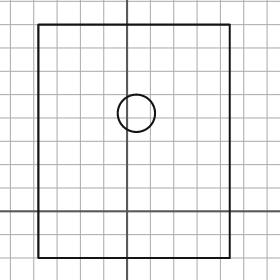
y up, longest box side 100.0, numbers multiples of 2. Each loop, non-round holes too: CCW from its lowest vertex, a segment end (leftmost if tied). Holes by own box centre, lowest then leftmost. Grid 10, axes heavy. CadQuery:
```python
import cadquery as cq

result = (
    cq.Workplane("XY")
    .moveTo(-38.0, -20.0)
    .lineTo(44.0, -20.0)
    .lineTo(44.0, 80.0)
    .lineTo(-38.0, 80.0)
    .close()
    .moveTo(4.0, 42.0)
    .circle(8.0)
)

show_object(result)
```